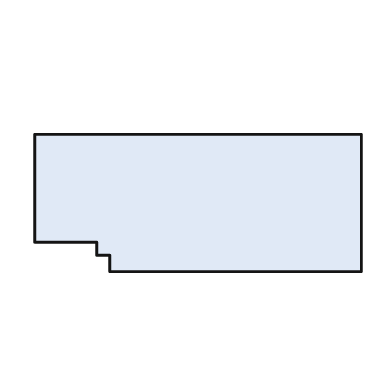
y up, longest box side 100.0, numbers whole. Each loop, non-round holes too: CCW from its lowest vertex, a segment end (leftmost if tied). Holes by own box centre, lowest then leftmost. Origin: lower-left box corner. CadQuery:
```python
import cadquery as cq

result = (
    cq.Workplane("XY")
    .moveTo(23.0, 0.0)
    .lineTo(100.0, 0.0)
    .lineTo(100.0, 42.0)
    .lineTo(0.0, 42.0)
    .lineTo(0.0, 9.0)
    .lineTo(19.0, 9.0)
    .lineTo(19.0, 5.0)
    .lineTo(23.0, 5.0)
    .close()
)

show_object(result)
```